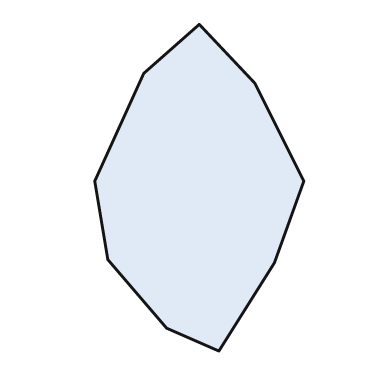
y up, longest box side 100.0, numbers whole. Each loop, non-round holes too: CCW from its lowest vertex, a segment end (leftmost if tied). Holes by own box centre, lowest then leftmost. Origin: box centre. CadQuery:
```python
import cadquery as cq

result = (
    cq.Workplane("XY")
    .moveTo(6.0, -50.0)
    .lineTo(23.0, -23.0)
    .lineTo(32.0, 2.0)
    .lineTo(17.0, 32.0)
    .lineTo(0.0, 50.0)
    .lineTo(-17.0, 35.0)
    .lineTo(-32.0, 2.0)
    .lineTo(-28.0, -22.0)
    .lineTo(-10.0, -43.0)
    .close()
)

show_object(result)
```